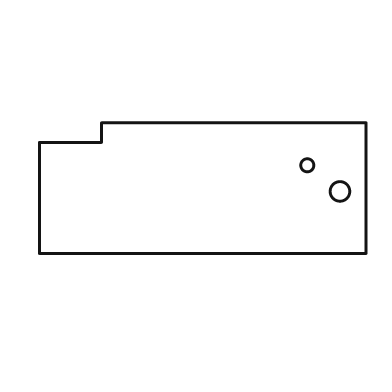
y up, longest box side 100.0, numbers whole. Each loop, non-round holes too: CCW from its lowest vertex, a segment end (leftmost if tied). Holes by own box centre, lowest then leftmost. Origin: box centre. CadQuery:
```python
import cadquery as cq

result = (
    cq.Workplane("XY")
    .moveTo(-50.0, -20.0)
    .lineTo(50.0, -20.0)
    .lineTo(50.0, 20.0)
    .lineTo(-31.0, 20.0)
    .lineTo(-31.0, 14.0)
    .lineTo(-50.0, 14.0)
    .close()
    .moveTo(42.0, -1.0)
    .circle(3.0)
    .moveTo(32.0, 7.0)
    .circle(2.0)
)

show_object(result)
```